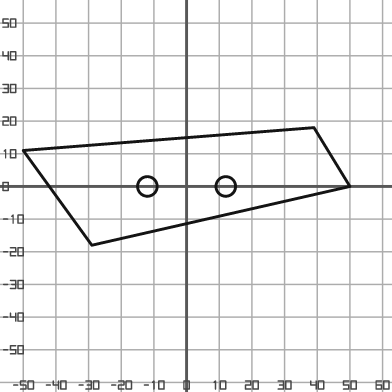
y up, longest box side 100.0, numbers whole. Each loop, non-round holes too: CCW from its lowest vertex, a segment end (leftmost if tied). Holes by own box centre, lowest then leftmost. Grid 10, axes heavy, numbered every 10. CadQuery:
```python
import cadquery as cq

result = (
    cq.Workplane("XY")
    .moveTo(-29.0, -18.0)
    .lineTo(50.0, 0.0)
    .lineTo(39.0, 18.0)
    .lineTo(-50.0, 11.0)
    .close()
    .moveTo(-12.0, 0.0)
    .circle(3.0)
    .moveTo(12.0, 0.0)
    .circle(3.0)
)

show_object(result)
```